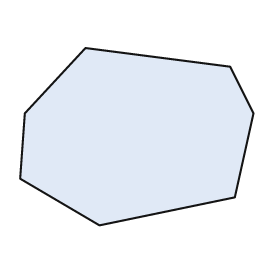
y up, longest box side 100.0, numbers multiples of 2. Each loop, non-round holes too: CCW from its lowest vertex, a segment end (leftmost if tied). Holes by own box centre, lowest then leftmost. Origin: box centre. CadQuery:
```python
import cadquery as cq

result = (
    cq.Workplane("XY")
    .moveTo(-16.0, -38.0)
    .lineTo(42.0, -26.0)
    .lineTo(50.0, 10.0)
    .lineTo(40.0, 30.0)
    .lineTo(-22.0, 38.0)
    .lineTo(-48.0, 10.0)
    .lineTo(-50.0, -18.0)
    .close()
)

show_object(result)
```